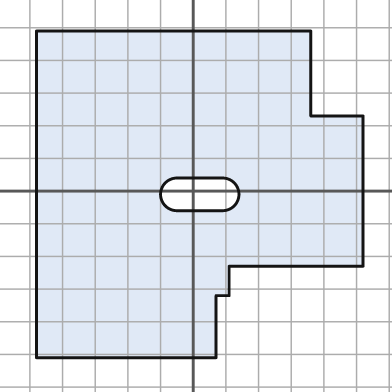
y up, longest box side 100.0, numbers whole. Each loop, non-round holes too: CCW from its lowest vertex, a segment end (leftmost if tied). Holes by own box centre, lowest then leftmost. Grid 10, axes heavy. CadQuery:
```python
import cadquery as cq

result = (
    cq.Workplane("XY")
    .moveTo(-48.0, -51.0)
    .lineTo(7.0, -51.0)
    .lineTo(7.0, -32.0)
    .lineTo(11.0, -32.0)
    .lineTo(11.0, -23.0)
    .lineTo(52.0, -23.0)
    .lineTo(52.0, 23.0)
    .lineTo(36.0, 23.0)
    .lineTo(36.0, 49.0)
    .lineTo(-48.0, 49.0)
    .close()
    .moveTo(-5.0, -6.0)
    .lineTo(9.0, -6.0)
    .threePointArc((14.0, -1.0), (9.0, 4.0))
    .lineTo(-5.0, 4.0)
    .threePointArc((-10.0, -1.0), (-5.0, -6.0))
    .close()
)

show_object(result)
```